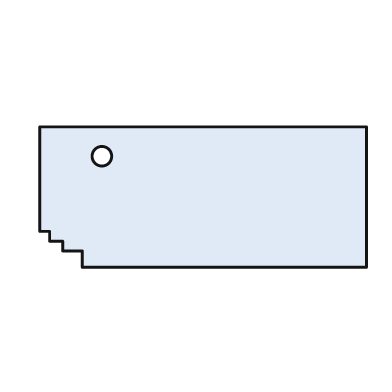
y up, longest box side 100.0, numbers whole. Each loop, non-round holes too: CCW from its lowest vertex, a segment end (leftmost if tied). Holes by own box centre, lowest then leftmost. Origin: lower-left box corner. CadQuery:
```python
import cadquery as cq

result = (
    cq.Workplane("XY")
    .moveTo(13.0, 0.0)
    .lineTo(100.0, 0.0)
    .lineTo(100.0, 43.0)
    .lineTo(0.0, 43.0)
    .lineTo(0.0, 11.0)
    .lineTo(3.0, 11.0)
    .lineTo(3.0, 8.0)
    .lineTo(7.0, 8.0)
    .lineTo(7.0, 5.0)
    .lineTo(13.0, 5.0)
    .close()
    .moveTo(19.0, 34.0)
    .circle(3.0)
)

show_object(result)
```